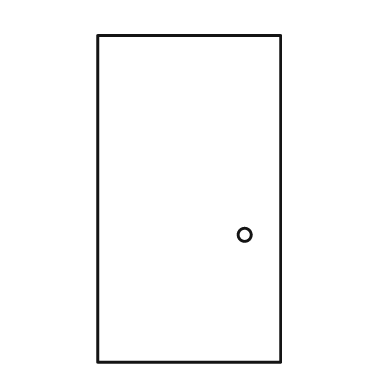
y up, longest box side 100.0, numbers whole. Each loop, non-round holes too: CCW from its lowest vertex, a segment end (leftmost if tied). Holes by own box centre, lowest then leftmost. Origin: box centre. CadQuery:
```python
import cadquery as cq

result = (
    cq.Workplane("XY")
    .moveTo(-28.0, -50.0)
    .lineTo(28.0, -50.0)
    .lineTo(28.0, 50.0)
    .lineTo(-28.0, 50.0)
    .close()
    .moveTo(17.0, -11.0)
    .circle(2.0)
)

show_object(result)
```